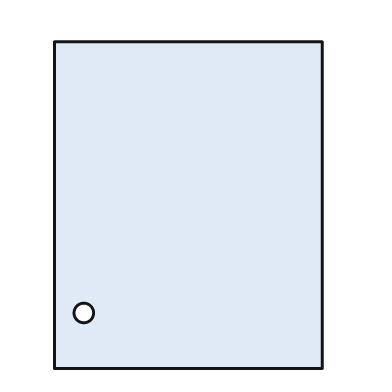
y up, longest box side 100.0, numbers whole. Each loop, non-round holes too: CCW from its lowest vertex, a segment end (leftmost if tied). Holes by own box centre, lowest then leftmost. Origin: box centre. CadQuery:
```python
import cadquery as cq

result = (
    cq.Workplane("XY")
    .moveTo(-41.0, -50.0)
    .lineTo(41.0, -50.0)
    .lineTo(41.0, 50.0)
    .lineTo(-41.0, 50.0)
    .close()
    .moveTo(-32.0, -33.0)
    .circle(3.0)
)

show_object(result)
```